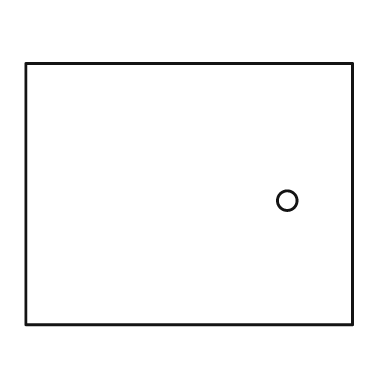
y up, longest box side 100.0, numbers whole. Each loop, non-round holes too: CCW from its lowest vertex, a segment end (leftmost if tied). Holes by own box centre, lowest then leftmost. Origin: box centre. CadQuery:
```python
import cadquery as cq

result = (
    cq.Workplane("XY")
    .moveTo(-50.0, -40.0)
    .lineTo(50.0, -40.0)
    .lineTo(50.0, 40.0)
    .lineTo(-50.0, 40.0)
    .close()
    .moveTo(30.0, -2.0)
    .circle(3.0)
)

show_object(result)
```